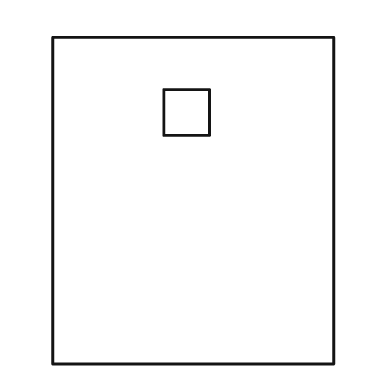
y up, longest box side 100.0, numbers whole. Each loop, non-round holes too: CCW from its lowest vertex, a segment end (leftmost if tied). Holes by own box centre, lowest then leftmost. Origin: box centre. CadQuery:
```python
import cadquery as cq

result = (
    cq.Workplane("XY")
    .moveTo(-43.0, -50.0)
    .lineTo(43.0, -50.0)
    .lineTo(43.0, 50.0)
    .lineTo(-43.0, 50.0)
    .close()
    .moveTo(-9.0, 20.0)
    .lineTo(5.0, 20.0)
    .lineTo(5.0, 34.0)
    .lineTo(-9.0, 34.0)
    .close()
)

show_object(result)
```